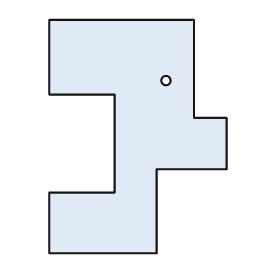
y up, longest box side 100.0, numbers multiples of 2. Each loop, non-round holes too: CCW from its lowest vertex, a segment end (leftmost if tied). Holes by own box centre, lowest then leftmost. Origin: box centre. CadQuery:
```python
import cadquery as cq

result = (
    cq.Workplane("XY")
    .moveTo(-38.0, -50.0)
    .lineTo(8.0, -50.0)
    .lineTo(8.0, -14.0)
    .lineTo(38.0, -14.0)
    .lineTo(38.0, 8.0)
    .lineTo(24.0, 8.0)
    .lineTo(24.0, 50.0)
    .lineTo(-38.0, 50.0)
    .lineTo(-38.0, 18.0)
    .lineTo(-10.0, 18.0)
    .lineTo(-10.0, -24.0)
    .lineTo(-38.0, -24.0)
    .close()
    .moveTo(12.0, 24.0)
    .circle(2.0)
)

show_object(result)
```